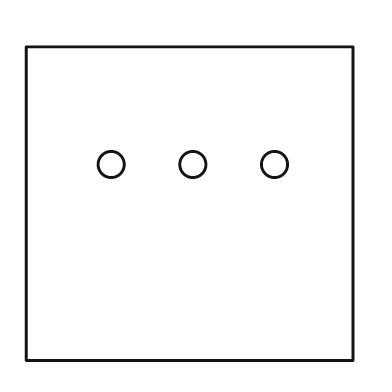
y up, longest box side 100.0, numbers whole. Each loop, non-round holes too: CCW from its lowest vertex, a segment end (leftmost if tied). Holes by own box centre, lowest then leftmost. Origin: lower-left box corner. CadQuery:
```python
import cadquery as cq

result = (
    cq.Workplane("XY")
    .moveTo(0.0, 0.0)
    .lineTo(100.0, 0.0)
    .lineTo(100.0, 96.0)
    .lineTo(0.0, 96.0)
    .close()
    .moveTo(26.0, 60.0)
    .circle(4.0)
    .moveTo(51.0, 60.0)
    .circle(4.0)
    .moveTo(76.0, 60.0)
    .circle(4.0)
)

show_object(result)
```